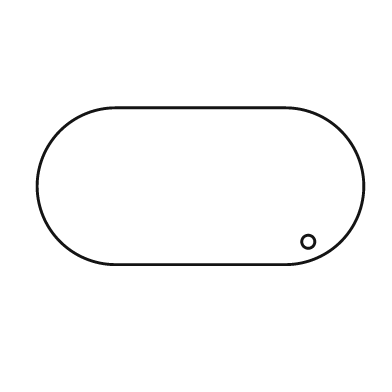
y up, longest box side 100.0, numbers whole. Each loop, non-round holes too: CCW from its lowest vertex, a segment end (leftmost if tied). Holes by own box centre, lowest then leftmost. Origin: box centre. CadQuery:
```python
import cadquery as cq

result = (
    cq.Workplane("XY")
    .moveTo(-26.0, -24.0)
    .lineTo(26.0, -24.0)
    .threePointArc((50.0, 0.0), (26.0, 24.0))
    .lineTo(-26.0, 24.0)
    .threePointArc((-50.0, 0.0), (-26.0, -24.0))
    .close()
    .moveTo(33.0, -17.0)
    .circle(2.0)
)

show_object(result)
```